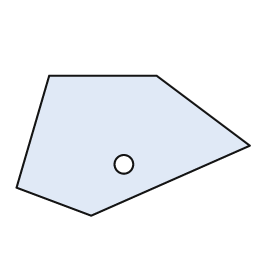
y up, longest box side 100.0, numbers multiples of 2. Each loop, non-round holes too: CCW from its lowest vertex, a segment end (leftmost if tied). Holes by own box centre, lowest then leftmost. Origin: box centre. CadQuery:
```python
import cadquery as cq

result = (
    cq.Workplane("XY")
    .moveTo(-18.0, -30.0)
    .lineTo(50.0, 0.0)
    .lineTo(10.0, 30.0)
    .lineTo(-36.0, 30.0)
    .lineTo(-50.0, -18.0)
    .close()
    .moveTo(-4.0, -8.0)
    .circle(4.0)
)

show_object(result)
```